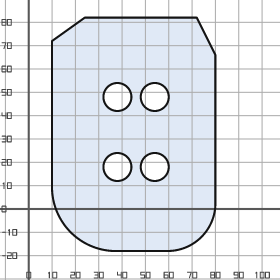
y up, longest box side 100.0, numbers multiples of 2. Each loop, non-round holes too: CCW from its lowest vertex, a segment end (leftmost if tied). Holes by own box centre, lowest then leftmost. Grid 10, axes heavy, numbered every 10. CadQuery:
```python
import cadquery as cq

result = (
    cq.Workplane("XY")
    .moveTo(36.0, -18.0)
    .lineTo(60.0, -18.0)
    .threePointArc((74.0, -12.0), (80.0, 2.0))
    .lineTo(80.0, 66.0)
    .lineTo(72.0, 82.0)
    .lineTo(24.0, 82.0)
    .lineTo(10.0, 72.0)
    .lineTo(10.0, 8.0)
    .threePointArc((18.0, -10.0), (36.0, -18.0))
    .close()
    .moveTo(38.0, 18.0)
    .circle(6.0)
    .moveTo(54.0, 18.0)
    .circle(6.0)
    .moveTo(38.0, 48.0)
    .circle(6.0)
    .moveTo(54.0, 48.0)
    .circle(6.0)
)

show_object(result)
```